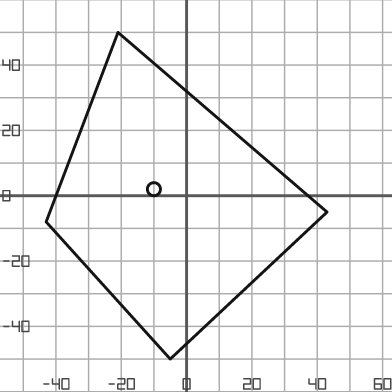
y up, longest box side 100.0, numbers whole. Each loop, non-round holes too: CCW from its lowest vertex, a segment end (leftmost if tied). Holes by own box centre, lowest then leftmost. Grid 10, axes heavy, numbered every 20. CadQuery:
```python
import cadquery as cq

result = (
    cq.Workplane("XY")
    .moveTo(-5.0, -50.0)
    .lineTo(43.0, -5.0)
    .lineTo(-21.0, 50.0)
    .lineTo(-43.0, -8.0)
    .close()
    .moveTo(-10.0, 2.0)
    .circle(2.0)
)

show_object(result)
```